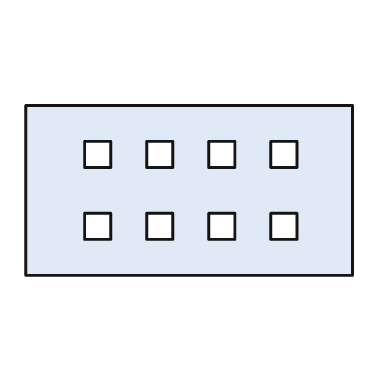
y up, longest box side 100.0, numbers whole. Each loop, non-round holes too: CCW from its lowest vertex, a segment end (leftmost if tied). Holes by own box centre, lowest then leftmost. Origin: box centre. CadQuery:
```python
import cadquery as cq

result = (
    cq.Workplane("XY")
    .moveTo(-50.0, -26.0)
    .lineTo(50.0, -26.0)
    .lineTo(50.0, 26.0)
    .lineTo(-50.0, 26.0)
    .close()
    .moveTo(-32.0, -15.0)
    .lineTo(-24.0, -15.0)
    .lineTo(-24.0, -7.0)
    .lineTo(-32.0, -7.0)
    .close()
    .moveTo(-13.0, -15.0)
    .lineTo(-5.0, -15.0)
    .lineTo(-5.0, -7.0)
    .lineTo(-13.0, -7.0)
    .close()
    .moveTo(6.0, -15.0)
    .lineTo(14.0, -15.0)
    .lineTo(14.0, -7.0)
    .lineTo(6.0, -7.0)
    .close()
    .moveTo(25.0, -15.0)
    .lineTo(33.0, -15.0)
    .lineTo(33.0, -7.0)
    .lineTo(25.0, -7.0)
    .close()
    .moveTo(-32.0, 7.0)
    .lineTo(-24.0, 7.0)
    .lineTo(-24.0, 15.0)
    .lineTo(-32.0, 15.0)
    .close()
    .moveTo(-13.0, 7.0)
    .lineTo(-5.0, 7.0)
    .lineTo(-5.0, 15.0)
    .lineTo(-13.0, 15.0)
    .close()
    .moveTo(6.0, 7.0)
    .lineTo(14.0, 7.0)
    .lineTo(14.0, 15.0)
    .lineTo(6.0, 15.0)
    .close()
    .moveTo(25.0, 7.0)
    .lineTo(33.0, 7.0)
    .lineTo(33.0, 15.0)
    .lineTo(25.0, 15.0)
    .close()
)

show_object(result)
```